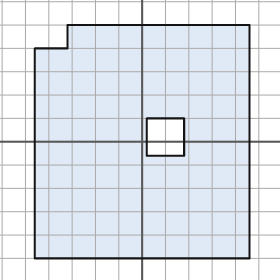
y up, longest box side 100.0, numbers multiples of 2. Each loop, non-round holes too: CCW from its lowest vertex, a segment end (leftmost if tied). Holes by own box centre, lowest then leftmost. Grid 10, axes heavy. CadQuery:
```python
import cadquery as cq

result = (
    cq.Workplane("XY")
    .moveTo(-46.0, -50.0)
    .lineTo(46.0, -50.0)
    .lineTo(46.0, 50.0)
    .lineTo(-32.0, 50.0)
    .lineTo(-32.0, 40.0)
    .lineTo(-46.0, 40.0)
    .close()
    .moveTo(2.0, -6.0)
    .lineTo(18.0, -6.0)
    .lineTo(18.0, 10.0)
    .lineTo(2.0, 10.0)
    .close()
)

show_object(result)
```